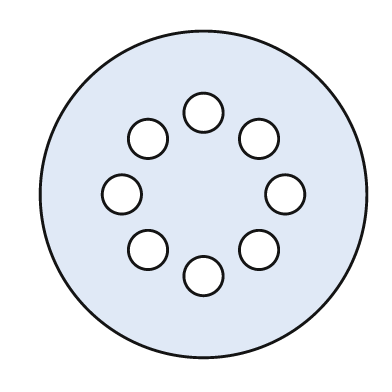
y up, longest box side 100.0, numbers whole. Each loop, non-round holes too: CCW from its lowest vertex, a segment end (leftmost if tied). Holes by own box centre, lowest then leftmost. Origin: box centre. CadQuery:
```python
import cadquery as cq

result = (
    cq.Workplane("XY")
    .moveTo(0.0, 0.0)
    .circle(50.0)
    .moveTo(0.0, -25.0)
    .circle(6.0)
    .moveTo(-17.0, -17.0)
    .circle(6.0)
    .moveTo(17.0, -17.0)
    .circle(6.0)
    .moveTo(-25.0, 0.0)
    .circle(6.0)
    .moveTo(25.0, 0.0)
    .circle(6.0)
    .moveTo(-17.0, 17.0)
    .circle(6.0)
    .moveTo(17.0, 17.0)
    .circle(6.0)
    .moveTo(0.0, 25.0)
    .circle(6.0)
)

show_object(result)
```